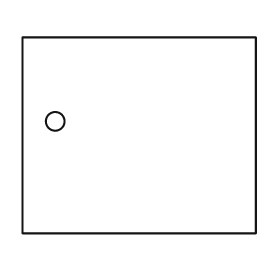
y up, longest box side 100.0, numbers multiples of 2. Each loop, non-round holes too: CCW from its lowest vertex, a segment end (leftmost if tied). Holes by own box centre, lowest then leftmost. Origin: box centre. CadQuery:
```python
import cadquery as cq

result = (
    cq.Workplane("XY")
    .moveTo(-50.0, -42.0)
    .lineTo(50.0, -42.0)
    .lineTo(50.0, 42.0)
    .lineTo(-50.0, 42.0)
    .close()
    .moveTo(-36.0, 6.0)
    .circle(4.0)
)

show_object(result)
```